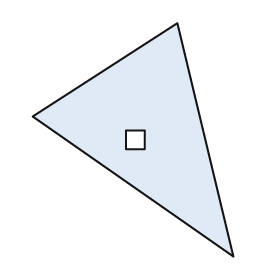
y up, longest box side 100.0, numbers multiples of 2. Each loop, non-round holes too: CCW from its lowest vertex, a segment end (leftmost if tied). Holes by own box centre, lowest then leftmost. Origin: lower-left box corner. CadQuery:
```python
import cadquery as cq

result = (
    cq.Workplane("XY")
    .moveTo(86.0, 0.0)
    .lineTo(62.0, 100.0)
    .lineTo(0.0, 60.0)
    .close()
    .moveTo(40.0, 46.0)
    .lineTo(48.0, 46.0)
    .lineTo(48.0, 54.0)
    .lineTo(40.0, 54.0)
    .close()
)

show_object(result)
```